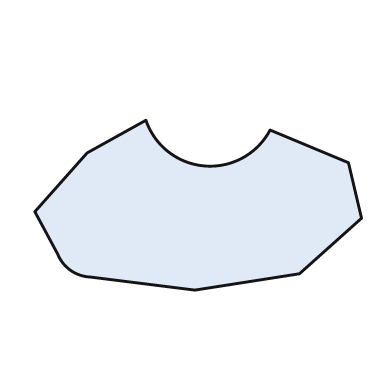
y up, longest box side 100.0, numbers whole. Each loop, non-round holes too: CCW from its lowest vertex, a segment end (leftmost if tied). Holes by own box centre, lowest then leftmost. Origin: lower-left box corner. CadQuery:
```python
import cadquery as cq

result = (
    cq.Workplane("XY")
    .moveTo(49.0, 0.0)
    .lineTo(81.0, 5.0)
    .lineTo(100.0, 22.0)
    .lineTo(96.0, 39.0)
    .lineTo(72.0, 49.0)
    .threePointArc((52.0, 38.0), (34.0, 52.0))
    .lineTo(16.0, 42.0)
    .lineTo(0.0, 24.0)
    .lineTo(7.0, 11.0)
    .threePointArc((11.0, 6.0), (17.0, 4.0))
    .close()
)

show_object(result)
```